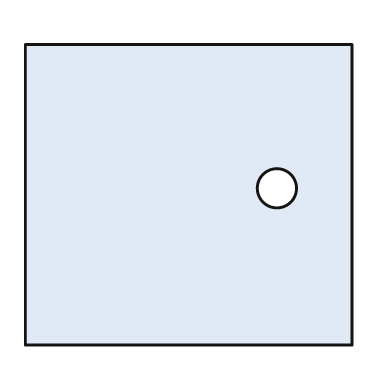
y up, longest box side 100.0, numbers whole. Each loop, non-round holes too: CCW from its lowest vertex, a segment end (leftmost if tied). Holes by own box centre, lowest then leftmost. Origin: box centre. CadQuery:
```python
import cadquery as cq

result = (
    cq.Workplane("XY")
    .moveTo(-50.0, -46.0)
    .lineTo(50.0, -46.0)
    .lineTo(50.0, 46.0)
    .lineTo(-50.0, 46.0)
    .close()
    .moveTo(27.0, 2.0)
    .circle(6.0)
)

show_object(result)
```